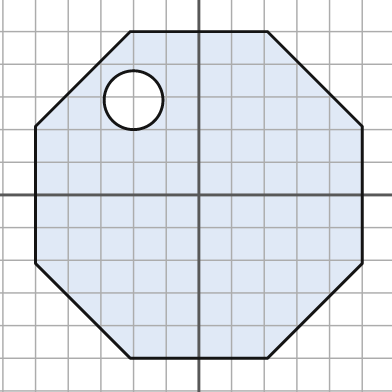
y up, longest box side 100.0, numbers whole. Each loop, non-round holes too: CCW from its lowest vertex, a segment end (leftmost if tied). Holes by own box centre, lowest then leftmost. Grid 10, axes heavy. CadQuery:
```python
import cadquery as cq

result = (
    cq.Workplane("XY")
    .moveTo(-21.0, -50.0)
    .lineTo(21.0, -50.0)
    .lineTo(50.0, -21.0)
    .lineTo(50.0, 21.0)
    .lineTo(21.0, 50.0)
    .lineTo(-21.0, 50.0)
    .lineTo(-50.0, 21.0)
    .lineTo(-50.0, -21.0)
    .close()
    .moveTo(-20.0, 29.0)
    .circle(9.0)
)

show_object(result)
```